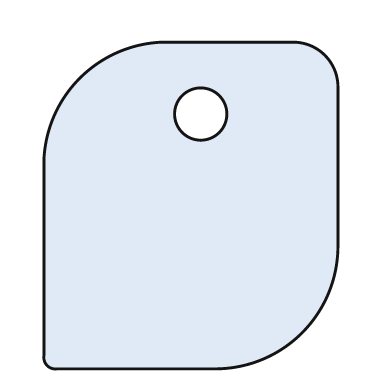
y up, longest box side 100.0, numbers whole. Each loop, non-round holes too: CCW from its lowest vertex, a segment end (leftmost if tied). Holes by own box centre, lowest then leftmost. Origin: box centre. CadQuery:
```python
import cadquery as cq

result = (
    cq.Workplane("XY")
    .moveTo(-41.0, -50.0)
    .lineTo(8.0, -50.0)
    .threePointArc((34.0, -39.0), (45.0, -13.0))
    .lineTo(45.0, 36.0)
    .threePointArc((41.0, 46.0), (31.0, 50.0))
    .lineTo(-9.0, 50.0)
    .threePointArc((-34.0, 39.0), (-45.0, 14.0))
    .lineTo(-45.0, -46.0)
    .threePointArc((-44.0, -49.0), (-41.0, -50.0))
    .close()
    .moveTo(3.0, 28.0)
    .circle(8.0)
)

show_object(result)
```